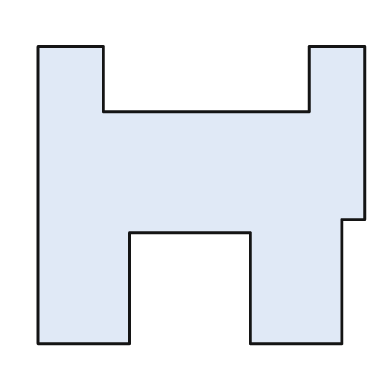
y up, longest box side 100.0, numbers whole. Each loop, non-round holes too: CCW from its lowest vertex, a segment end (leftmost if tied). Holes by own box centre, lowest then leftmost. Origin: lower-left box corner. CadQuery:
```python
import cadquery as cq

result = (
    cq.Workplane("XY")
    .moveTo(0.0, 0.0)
    .lineTo(28.0, 0.0)
    .lineTo(28.0, 34.0)
    .lineTo(65.0, 34.0)
    .lineTo(65.0, 0.0)
    .lineTo(93.0, 0.0)
    .lineTo(93.0, 38.0)
    .lineTo(100.0, 38.0)
    .lineTo(100.0, 91.0)
    .lineTo(83.0, 91.0)
    .lineTo(83.0, 71.0)
    .lineTo(20.0, 71.0)
    .lineTo(20.0, 91.0)
    .lineTo(0.0, 91.0)
    .close()
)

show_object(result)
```